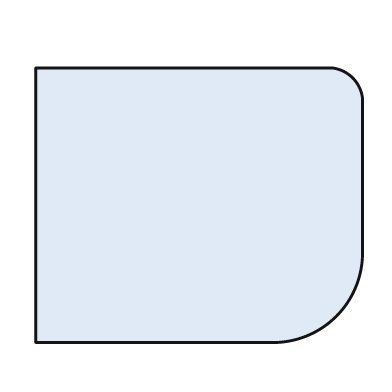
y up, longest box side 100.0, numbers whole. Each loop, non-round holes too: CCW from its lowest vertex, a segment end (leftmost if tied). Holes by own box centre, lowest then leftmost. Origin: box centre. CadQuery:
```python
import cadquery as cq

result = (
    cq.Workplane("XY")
    .moveTo(-50.0, -42.0)
    .lineTo(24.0, -42.0)
    .threePointArc((42.0, -34.0), (50.0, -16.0))
    .lineTo(50.0, 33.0)
    .threePointArc((47.0, 39.0), (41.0, 42.0))
    .lineTo(-50.0, 42.0)
    .close()
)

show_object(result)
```